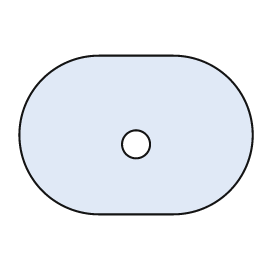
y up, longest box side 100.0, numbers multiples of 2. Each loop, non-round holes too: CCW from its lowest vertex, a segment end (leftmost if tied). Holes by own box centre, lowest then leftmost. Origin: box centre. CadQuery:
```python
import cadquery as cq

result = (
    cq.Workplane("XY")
    .moveTo(-16.0, -34.0)
    .lineTo(16.0, -34.0)
    .threePointArc((50.0, 0.0), (16.0, 34.0))
    .lineTo(-16.0, 34.0)
    .threePointArc((-50.0, 0.0), (-16.0, -34.0))
    .close()
    .moveTo(0.0, -4.0)
    .circle(6.0)
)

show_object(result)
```